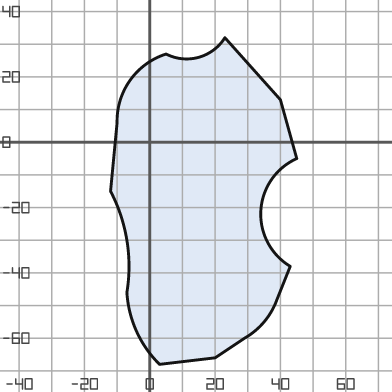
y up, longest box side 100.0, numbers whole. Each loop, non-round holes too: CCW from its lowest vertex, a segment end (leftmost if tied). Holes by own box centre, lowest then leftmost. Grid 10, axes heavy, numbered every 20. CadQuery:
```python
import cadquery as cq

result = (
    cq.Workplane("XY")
    .moveTo(3.0, -68.0)
    .lineTo(20.0, -66.0)
    .lineTo(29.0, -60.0)
    .threePointArc((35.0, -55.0), (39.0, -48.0))
    .lineTo(43.0, -38.0)
    .threePointArc((34.0, -21.0), (45.0, -5.0))
    .lineTo(40.0, 13.0)
    .lineTo(23.0, 32.0)
    .threePointArc((15.0, 26.0), (5.0, 27.0))
    .threePointArc((-6.0, 19.0), (-10.0, 6.0))
    .lineTo(-12.0, -15.0)
    .threePointArc((-7.0, -30.0), (-7.0, -46.0))
    .threePointArc((-4.0, -58.0), (3.0, -68.0))
    .close()
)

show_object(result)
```